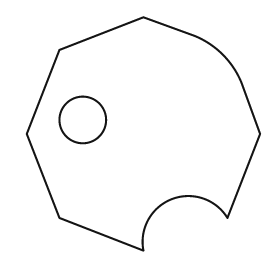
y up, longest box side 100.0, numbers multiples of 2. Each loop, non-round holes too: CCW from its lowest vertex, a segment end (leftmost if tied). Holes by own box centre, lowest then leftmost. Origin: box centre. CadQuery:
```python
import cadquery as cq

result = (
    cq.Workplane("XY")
    .moveTo(0.0, -50.0)
    .threePointArc((12.0, -28.0), (36.0, -36.0))
    .lineTo(50.0, 0.0)
    .lineTo(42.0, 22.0)
    .threePointArc((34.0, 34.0), (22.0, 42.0))
    .lineTo(0.0, 50.0)
    .lineTo(-36.0, 36.0)
    .lineTo(-50.0, 0.0)
    .lineTo(-36.0, -36.0)
    .close()
    .moveTo(-26.0, 6.0)
    .circle(10.0)
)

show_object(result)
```